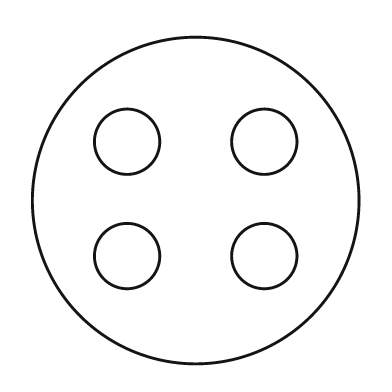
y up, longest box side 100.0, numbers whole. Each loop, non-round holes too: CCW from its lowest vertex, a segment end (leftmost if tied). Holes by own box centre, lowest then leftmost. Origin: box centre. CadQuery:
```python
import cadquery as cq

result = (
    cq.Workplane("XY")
    .moveTo(0.0, 0.0)
    .circle(50.0)
    .moveTo(-21.0, -17.0)
    .circle(10.0)
    .moveTo(21.0, -17.0)
    .circle(10.0)
    .moveTo(-21.0, 18.0)
    .circle(10.0)
    .moveTo(21.0, 18.0)
    .circle(10.0)
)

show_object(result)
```